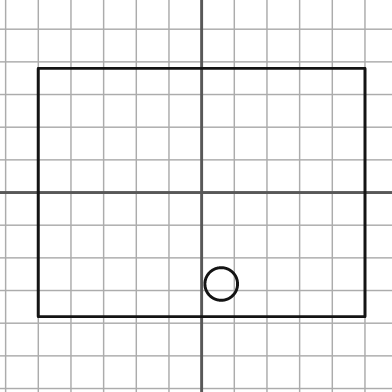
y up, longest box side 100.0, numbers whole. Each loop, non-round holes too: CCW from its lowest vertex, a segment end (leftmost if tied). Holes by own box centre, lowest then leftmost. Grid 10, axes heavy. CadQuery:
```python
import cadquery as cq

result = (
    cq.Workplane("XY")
    .moveTo(-50.0, -38.0)
    .lineTo(50.0, -38.0)
    .lineTo(50.0, 38.0)
    .lineTo(-50.0, 38.0)
    .close()
    .moveTo(6.0, -28.0)
    .circle(5.0)
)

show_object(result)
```